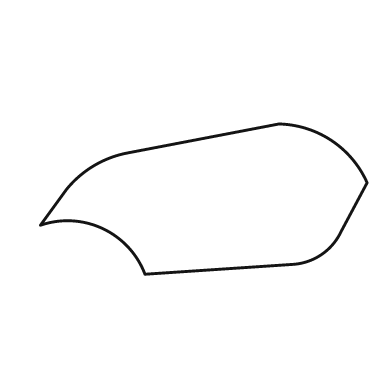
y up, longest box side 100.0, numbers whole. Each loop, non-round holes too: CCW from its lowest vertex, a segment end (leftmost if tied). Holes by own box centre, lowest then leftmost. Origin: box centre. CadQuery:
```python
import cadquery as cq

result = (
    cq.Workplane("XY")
    .moveTo(-18.0, -23.0)
    .lineTo(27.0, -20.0)
    .threePointArc((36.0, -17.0), (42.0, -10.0))
    .lineTo(50.0, 5.0)
    .threePointArc((39.0, 18.0), (23.0, 23.0))
    .lineTo(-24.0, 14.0)
    .threePointArc((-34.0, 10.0), (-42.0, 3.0))
    .lineTo(-50.0, -8.0)
    .threePointArc((-31.0, -9.0), (-18.0, -23.0))
    .close()
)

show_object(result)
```